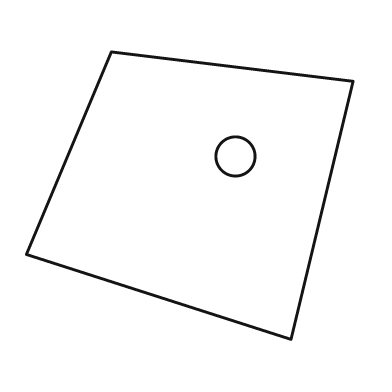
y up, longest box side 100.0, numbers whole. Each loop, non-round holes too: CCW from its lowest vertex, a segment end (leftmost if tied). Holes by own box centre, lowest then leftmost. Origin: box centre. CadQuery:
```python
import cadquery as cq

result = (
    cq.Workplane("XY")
    .moveTo(31.0, -44.0)
    .lineTo(50.0, 35.0)
    .lineTo(-24.0, 44.0)
    .lineTo(-50.0, -18.0)
    .close()
    .moveTo(14.0, 12.0)
    .circle(6.0)
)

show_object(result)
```